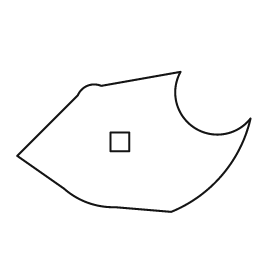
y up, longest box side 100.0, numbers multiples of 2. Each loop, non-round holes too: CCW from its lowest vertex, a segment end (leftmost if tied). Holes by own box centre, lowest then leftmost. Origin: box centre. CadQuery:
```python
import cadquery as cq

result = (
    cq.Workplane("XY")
    .moveTo(16.0, -30.0)
    .threePointArc((38.0, -14.0), (50.0, 10.0))
    .threePointArc((26.0, 6.0), (20.0, 30.0))
    .lineTo(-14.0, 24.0)
    .threePointArc((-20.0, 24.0), (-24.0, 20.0))
    .lineTo(-50.0, -6.0)
    .lineTo(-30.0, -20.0)
    .threePointArc((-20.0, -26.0), (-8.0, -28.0))
    .close()
    .moveTo(-10.0, -4.0)
    .lineTo(-2.0, -4.0)
    .lineTo(-2.0, 4.0)
    .lineTo(-10.0, 4.0)
    .close()
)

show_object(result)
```